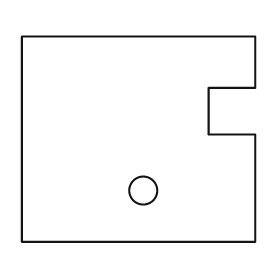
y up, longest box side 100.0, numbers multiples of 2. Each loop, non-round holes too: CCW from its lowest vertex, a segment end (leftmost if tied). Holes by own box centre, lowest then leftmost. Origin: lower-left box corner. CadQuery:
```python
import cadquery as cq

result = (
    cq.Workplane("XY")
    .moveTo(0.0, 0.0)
    .lineTo(100.0, 0.0)
    .lineTo(100.0, 46.0)
    .lineTo(80.0, 46.0)
    .lineTo(80.0, 66.0)
    .lineTo(100.0, 66.0)
    .lineTo(100.0, 88.0)
    .lineTo(0.0, 88.0)
    .close()
    .moveTo(52.0, 22.0)
    .circle(6.0)
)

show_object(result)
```